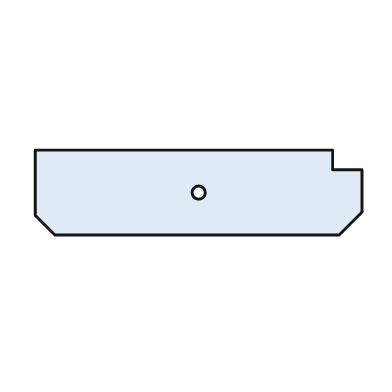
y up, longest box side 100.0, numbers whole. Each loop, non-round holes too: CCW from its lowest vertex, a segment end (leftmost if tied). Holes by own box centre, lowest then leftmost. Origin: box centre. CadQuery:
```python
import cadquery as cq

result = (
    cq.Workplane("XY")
    .moveTo(-44.0, -13.0)
    .lineTo(43.0, -13.0)
    .lineTo(50.0, -6.0)
    .lineTo(50.0, 7.0)
    .lineTo(41.0, 7.0)
    .lineTo(41.0, 13.0)
    .lineTo(-50.0, 13.0)
    .lineTo(-50.0, -7.0)
    .close()
    .moveTo(0.0, 0.0)
    .circle(2.0)
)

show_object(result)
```